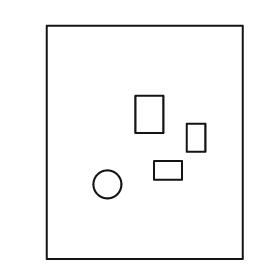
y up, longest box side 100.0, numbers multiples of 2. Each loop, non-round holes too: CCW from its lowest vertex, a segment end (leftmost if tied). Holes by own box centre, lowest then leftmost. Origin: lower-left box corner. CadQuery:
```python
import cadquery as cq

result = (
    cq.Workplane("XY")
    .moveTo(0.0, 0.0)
    .lineTo(84.0, 0.0)
    .lineTo(84.0, 100.0)
    .lineTo(0.0, 100.0)
    .close()
    .moveTo(26.0, 32.0)
    .circle(6.0)
    .moveTo(46.0, 34.0)
    .lineTo(58.0, 34.0)
    .lineTo(58.0, 42.0)
    .lineTo(46.0, 42.0)
    .close()
    .moveTo(60.0, 46.0)
    .lineTo(68.0, 46.0)
    .lineTo(68.0, 58.0)
    .lineTo(60.0, 58.0)
    .close()
    .moveTo(38.0, 54.0)
    .lineTo(50.0, 54.0)
    .lineTo(50.0, 70.0)
    .lineTo(38.0, 70.0)
    .close()
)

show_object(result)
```